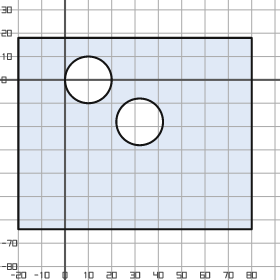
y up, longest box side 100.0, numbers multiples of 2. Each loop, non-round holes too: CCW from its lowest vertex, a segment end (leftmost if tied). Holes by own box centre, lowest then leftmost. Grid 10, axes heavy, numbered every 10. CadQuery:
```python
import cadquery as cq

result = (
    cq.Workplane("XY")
    .moveTo(-20.0, -64.0)
    .lineTo(80.0, -64.0)
    .lineTo(80.0, 18.0)
    .lineTo(-20.0, 18.0)
    .close()
    .moveTo(32.0, -18.0)
    .circle(10.0)
    .moveTo(10.0, 0.0)
    .circle(10.0)
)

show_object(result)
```